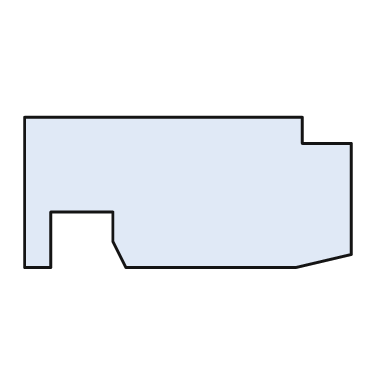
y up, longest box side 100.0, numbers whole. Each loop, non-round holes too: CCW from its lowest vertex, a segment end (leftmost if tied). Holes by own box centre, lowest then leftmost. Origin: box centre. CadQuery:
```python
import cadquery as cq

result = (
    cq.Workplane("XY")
    .moveTo(-50.0, -23.0)
    .lineTo(-42.0, -23.0)
    .lineTo(-42.0, -6.0)
    .lineTo(-23.0, -6.0)
    .lineTo(-23.0, -15.0)
    .lineTo(-19.0, -23.0)
    .lineTo(33.0, -23.0)
    .lineTo(50.0, -19.0)
    .lineTo(50.0, 15.0)
    .lineTo(35.0, 15.0)
    .lineTo(35.0, 23.0)
    .lineTo(-50.0, 23.0)
    .close()
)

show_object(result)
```